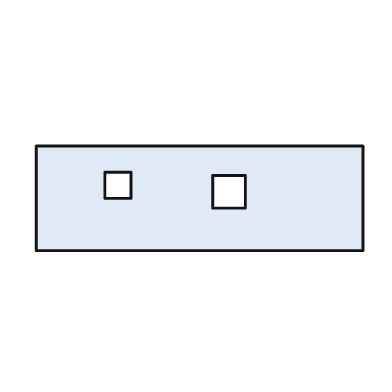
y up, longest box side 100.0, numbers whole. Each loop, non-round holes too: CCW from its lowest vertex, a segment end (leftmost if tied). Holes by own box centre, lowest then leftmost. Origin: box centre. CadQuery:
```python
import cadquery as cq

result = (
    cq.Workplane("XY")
    .moveTo(-50.0, -16.0)
    .lineTo(50.0, -16.0)
    .lineTo(50.0, 16.0)
    .lineTo(-50.0, 16.0)
    .close()
    .moveTo(4.0, -3.0)
    .lineTo(14.0, -3.0)
    .lineTo(14.0, 7.0)
    .lineTo(4.0, 7.0)
    .close()
    .moveTo(-29.0, 0.0)
    .lineTo(-21.0, 0.0)
    .lineTo(-21.0, 8.0)
    .lineTo(-29.0, 8.0)
    .close()
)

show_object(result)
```